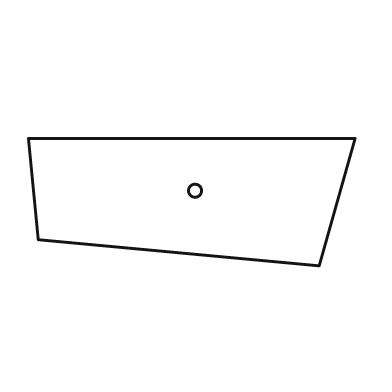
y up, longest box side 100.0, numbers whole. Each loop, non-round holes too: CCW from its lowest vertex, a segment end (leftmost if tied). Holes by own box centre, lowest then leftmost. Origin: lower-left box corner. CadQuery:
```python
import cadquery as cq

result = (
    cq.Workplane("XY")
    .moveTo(89.0, 0.0)
    .lineTo(100.0, 39.0)
    .lineTo(0.0, 39.0)
    .lineTo(3.0, 8.0)
    .close()
    .moveTo(51.0, 23.0)
    .circle(2.0)
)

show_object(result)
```